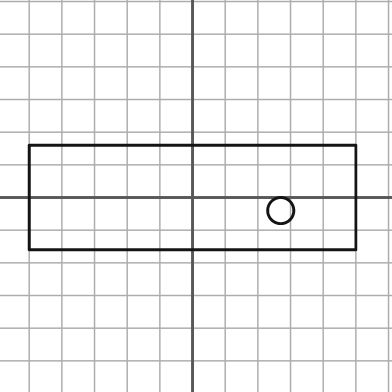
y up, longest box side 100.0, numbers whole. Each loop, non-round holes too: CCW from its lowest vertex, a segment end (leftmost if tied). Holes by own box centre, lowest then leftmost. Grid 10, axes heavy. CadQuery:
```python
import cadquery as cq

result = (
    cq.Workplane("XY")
    .moveTo(-50.0, -16.0)
    .lineTo(50.0, -16.0)
    .lineTo(50.0, 16.0)
    .lineTo(-50.0, 16.0)
    .close()
    .moveTo(27.0, -4.0)
    .circle(4.0)
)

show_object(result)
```